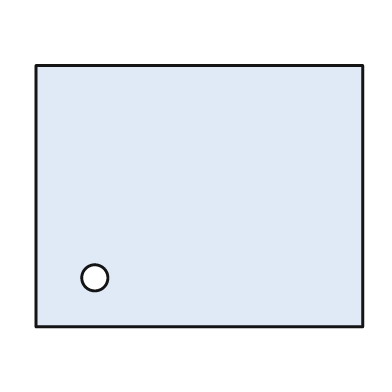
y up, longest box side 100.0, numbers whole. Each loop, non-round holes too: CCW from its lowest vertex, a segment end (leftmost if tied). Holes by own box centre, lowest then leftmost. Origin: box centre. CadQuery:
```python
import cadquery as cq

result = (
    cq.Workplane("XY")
    .moveTo(-50.0, -40.0)
    .lineTo(50.0, -40.0)
    .lineTo(50.0, 40.0)
    .lineTo(-50.0, 40.0)
    .close()
    .moveTo(-32.0, -25.0)
    .circle(4.0)
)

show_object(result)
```